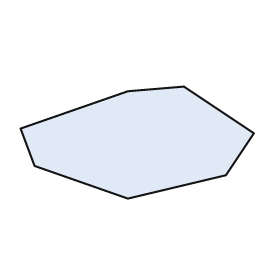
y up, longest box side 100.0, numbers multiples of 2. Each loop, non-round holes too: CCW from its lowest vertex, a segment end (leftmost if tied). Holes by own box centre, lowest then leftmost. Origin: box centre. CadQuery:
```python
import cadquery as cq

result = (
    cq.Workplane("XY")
    .moveTo(-4.0, -24.0)
    .lineTo(38.0, -14.0)
    .lineTo(50.0, 4.0)
    .lineTo(20.0, 24.0)
    .lineTo(-4.0, 22.0)
    .lineTo(-50.0, 6.0)
    .lineTo(-44.0, -10.0)
    .close()
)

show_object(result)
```